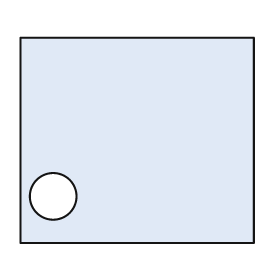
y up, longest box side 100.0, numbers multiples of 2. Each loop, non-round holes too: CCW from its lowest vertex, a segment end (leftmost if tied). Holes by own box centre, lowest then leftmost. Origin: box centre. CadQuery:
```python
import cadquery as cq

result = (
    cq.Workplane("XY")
    .moveTo(-50.0, -44.0)
    .lineTo(50.0, -44.0)
    .lineTo(50.0, 44.0)
    .lineTo(-50.0, 44.0)
    .close()
    .moveTo(-36.0, -24.0)
    .circle(10.0)
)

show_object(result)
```